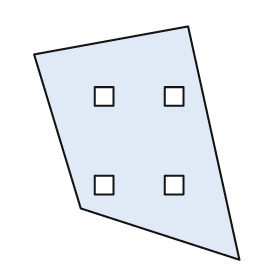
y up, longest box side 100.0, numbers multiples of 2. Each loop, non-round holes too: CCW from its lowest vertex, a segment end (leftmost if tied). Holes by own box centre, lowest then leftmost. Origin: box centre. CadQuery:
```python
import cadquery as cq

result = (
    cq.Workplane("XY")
    .moveTo(44.0, -50.0)
    .lineTo(22.0, 50.0)
    .lineTo(-44.0, 38.0)
    .lineTo(-24.0, -28.0)
    .close()
    .moveTo(-18.0, -22.0)
    .lineTo(-10.0, -22.0)
    .lineTo(-10.0, -14.0)
    .lineTo(-18.0, -14.0)
    .close()
    .moveTo(12.0, -22.0)
    .lineTo(20.0, -22.0)
    .lineTo(20.0, -14.0)
    .lineTo(12.0, -14.0)
    .close()
    .moveTo(-18.0, 16.0)
    .lineTo(-10.0, 16.0)
    .lineTo(-10.0, 24.0)
    .lineTo(-18.0, 24.0)
    .close()
    .moveTo(12.0, 16.0)
    .lineTo(20.0, 16.0)
    .lineTo(20.0, 24.0)
    .lineTo(12.0, 24.0)
    .close()
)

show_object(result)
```